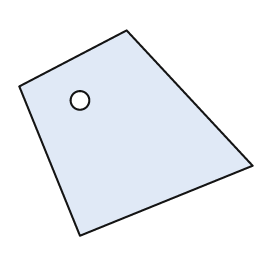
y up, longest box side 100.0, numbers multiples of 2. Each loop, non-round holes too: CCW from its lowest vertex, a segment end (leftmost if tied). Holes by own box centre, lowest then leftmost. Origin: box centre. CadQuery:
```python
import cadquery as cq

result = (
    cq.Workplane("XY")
    .moveTo(-24.0, -44.0)
    .lineTo(50.0, -14.0)
    .lineTo(-4.0, 44.0)
    .lineTo(-50.0, 20.0)
    .close()
    .moveTo(-24.0, 14.0)
    .circle(4.0)
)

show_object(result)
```